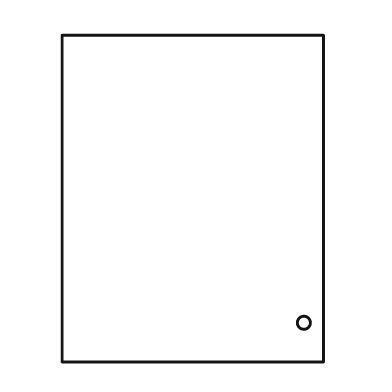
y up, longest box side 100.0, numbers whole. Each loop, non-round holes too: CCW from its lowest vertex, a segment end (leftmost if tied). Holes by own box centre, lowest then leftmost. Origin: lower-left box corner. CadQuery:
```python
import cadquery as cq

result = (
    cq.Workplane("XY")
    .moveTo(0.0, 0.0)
    .lineTo(80.0, 0.0)
    .lineTo(80.0, 100.0)
    .lineTo(0.0, 100.0)
    .close()
    .moveTo(74.0, 12.0)
    .circle(2.0)
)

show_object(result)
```